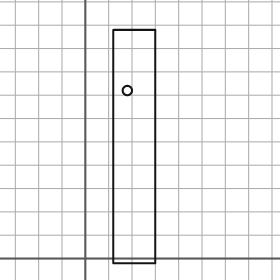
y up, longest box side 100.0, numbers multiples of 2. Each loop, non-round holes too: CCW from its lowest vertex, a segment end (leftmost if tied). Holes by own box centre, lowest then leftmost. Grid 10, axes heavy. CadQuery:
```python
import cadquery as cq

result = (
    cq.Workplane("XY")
    .moveTo(12.0, -2.0)
    .lineTo(30.0, -2.0)
    .lineTo(30.0, 98.0)
    .lineTo(12.0, 98.0)
    .close()
    .moveTo(18.0, 72.0)
    .circle(2.0)
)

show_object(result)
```